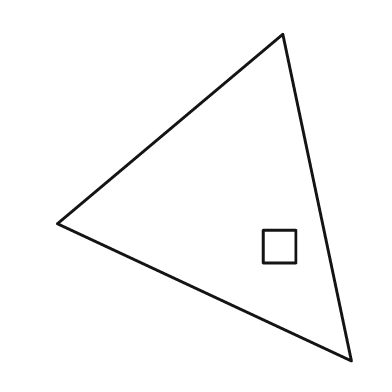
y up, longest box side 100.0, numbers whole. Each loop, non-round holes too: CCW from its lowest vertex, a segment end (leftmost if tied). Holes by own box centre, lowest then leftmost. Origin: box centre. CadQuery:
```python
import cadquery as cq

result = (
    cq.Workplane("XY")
    .moveTo(45.0, -50.0)
    .lineTo(24.0, 50.0)
    .lineTo(-45.0, -8.0)
    .close()
    .moveTo(18.0, -20.0)
    .lineTo(28.0, -20.0)
    .lineTo(28.0, -10.0)
    .lineTo(18.0, -10.0)
    .close()
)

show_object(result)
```